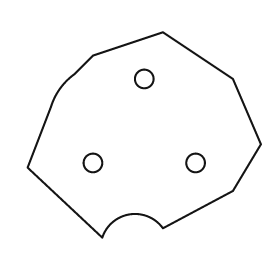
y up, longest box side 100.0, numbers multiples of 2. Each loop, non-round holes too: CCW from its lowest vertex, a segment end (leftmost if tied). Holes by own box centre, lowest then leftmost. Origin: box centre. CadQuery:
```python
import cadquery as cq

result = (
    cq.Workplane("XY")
    .moveTo(-18.0, -44.0)
    .threePointArc((-6.0, -34.0), (8.0, -40.0))
    .lineTo(38.0, -24.0)
    .lineTo(50.0, -4.0)
    .lineTo(38.0, 24.0)
    .lineTo(8.0, 44.0)
    .lineTo(-22.0, 34.0)
    .lineTo(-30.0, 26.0)
    .threePointArc((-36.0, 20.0), (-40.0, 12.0))
    .lineTo(-50.0, -14.0)
    .close()
    .moveTo(-22.0, -12.0)
    .circle(4.0)
    .moveTo(22.0, -12.0)
    .circle(4.0)
    .moveTo(0.0, 24.0)
    .circle(4.0)
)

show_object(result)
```